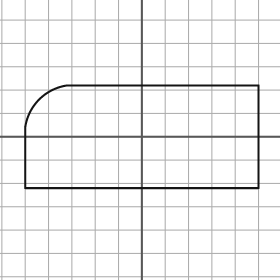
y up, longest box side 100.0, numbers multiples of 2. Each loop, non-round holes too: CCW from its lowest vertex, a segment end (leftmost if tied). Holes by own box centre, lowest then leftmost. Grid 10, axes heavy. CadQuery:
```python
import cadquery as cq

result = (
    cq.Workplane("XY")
    .moveTo(-50.0, -22.0)
    .lineTo(50.0, -22.0)
    .lineTo(50.0, 22.0)
    .lineTo(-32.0, 22.0)
    .threePointArc((-44.0, 16.0), (-50.0, 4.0))
    .close()
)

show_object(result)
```